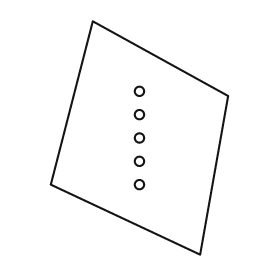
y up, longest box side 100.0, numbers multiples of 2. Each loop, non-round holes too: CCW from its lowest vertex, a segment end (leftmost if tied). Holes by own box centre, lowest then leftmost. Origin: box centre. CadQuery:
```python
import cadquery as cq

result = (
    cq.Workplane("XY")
    .moveTo(26.0, -50.0)
    .lineTo(38.0, 18.0)
    .lineTo(-20.0, 50.0)
    .lineTo(-38.0, -20.0)
    .close()
    .moveTo(0.0, -20.0)
    .circle(2.0)
    .moveTo(0.0, -10.0)
    .circle(2.0)
    .moveTo(0.0, 0.0)
    .circle(2.0)
    .moveTo(0.0, 10.0)
    .circle(2.0)
    .moveTo(0.0, 20.0)
    .circle(2.0)
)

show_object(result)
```